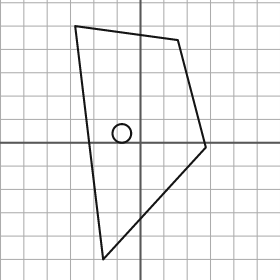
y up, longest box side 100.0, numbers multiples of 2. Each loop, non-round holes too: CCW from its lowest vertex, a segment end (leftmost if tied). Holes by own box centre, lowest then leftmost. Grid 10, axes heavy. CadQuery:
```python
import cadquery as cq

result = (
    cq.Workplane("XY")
    .moveTo(-16.0, -50.0)
    .lineTo(28.0, -2.0)
    .lineTo(16.0, 44.0)
    .lineTo(-28.0, 50.0)
    .close()
    .moveTo(-8.0, 4.0)
    .circle(4.0)
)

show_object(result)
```